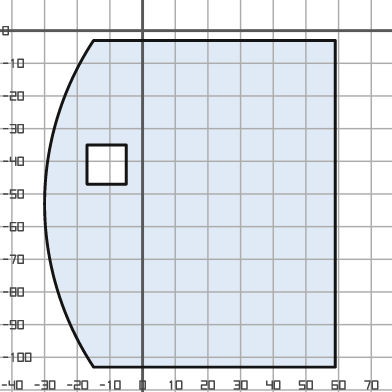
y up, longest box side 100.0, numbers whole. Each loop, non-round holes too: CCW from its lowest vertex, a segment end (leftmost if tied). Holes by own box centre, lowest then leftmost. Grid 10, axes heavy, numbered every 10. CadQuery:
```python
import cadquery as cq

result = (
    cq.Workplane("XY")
    .moveTo(-15.0, -103.0)
    .lineTo(59.0, -103.0)
    .lineTo(59.0, -3.0)
    .lineTo(-15.0, -3.0)
    .threePointArc((-30.0, -53.0), (-15.0, -103.0))
    .close()
    .moveTo(-17.0, -47.0)
    .lineTo(-5.0, -47.0)
    .lineTo(-5.0, -35.0)
    .lineTo(-17.0, -35.0)
    .close()
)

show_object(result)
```